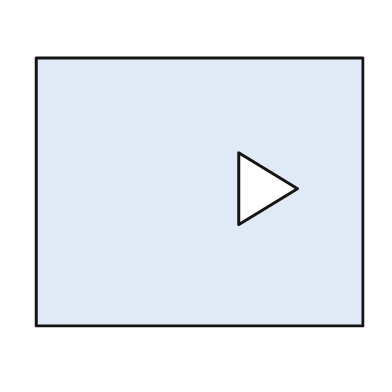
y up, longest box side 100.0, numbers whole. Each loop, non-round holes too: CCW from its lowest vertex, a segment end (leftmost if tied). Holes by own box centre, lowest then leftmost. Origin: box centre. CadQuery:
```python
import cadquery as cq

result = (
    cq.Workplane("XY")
    .moveTo(-50.0, -41.0)
    .lineTo(50.0, -41.0)
    .lineTo(50.0, 41.0)
    .lineTo(-50.0, 41.0)
    .close()
    .moveTo(12.0, -10.0)
    .lineTo(30.0, 1.0)
    .lineTo(12.0, 12.0)
    .close()
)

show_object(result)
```